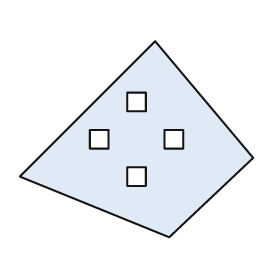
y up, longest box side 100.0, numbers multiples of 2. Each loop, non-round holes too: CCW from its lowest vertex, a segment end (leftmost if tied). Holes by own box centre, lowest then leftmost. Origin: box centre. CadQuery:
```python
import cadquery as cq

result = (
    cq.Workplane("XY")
    .moveTo(14.0, -42.0)
    .lineTo(50.0, -8.0)
    .lineTo(8.0, 42.0)
    .lineTo(-50.0, -16.0)
    .close()
    .moveTo(-4.0, -20.0)
    .lineTo(4.0, -20.0)
    .lineTo(4.0, -12.0)
    .lineTo(-4.0, -12.0)
    .close()
    .moveTo(-20.0, -4.0)
    .lineTo(-12.0, -4.0)
    .lineTo(-12.0, 4.0)
    .lineTo(-20.0, 4.0)
    .close()
    .moveTo(12.0, -4.0)
    .lineTo(20.0, -4.0)
    .lineTo(20.0, 4.0)
    .lineTo(12.0, 4.0)
    .close()
    .moveTo(-4.0, 12.0)
    .lineTo(4.0, 12.0)
    .lineTo(4.0, 20.0)
    .lineTo(-4.0, 20.0)
    .close()
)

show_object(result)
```